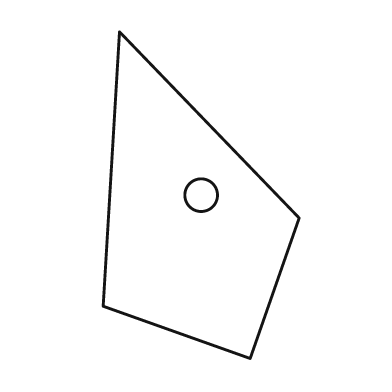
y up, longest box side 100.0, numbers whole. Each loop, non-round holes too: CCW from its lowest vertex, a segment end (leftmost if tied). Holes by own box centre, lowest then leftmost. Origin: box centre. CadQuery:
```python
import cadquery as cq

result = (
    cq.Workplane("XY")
    .moveTo(15.0, -50.0)
    .lineTo(30.0, -7.0)
    .lineTo(-25.0, 50.0)
    .lineTo(-30.0, -34.0)
    .close()
    .moveTo(0.0, 0.0)
    .circle(5.0)
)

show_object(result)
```